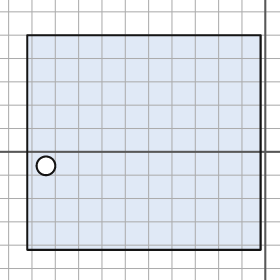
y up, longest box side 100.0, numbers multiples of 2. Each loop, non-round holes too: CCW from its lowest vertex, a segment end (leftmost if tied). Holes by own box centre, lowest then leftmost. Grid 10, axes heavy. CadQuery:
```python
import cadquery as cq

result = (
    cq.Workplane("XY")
    .moveTo(-102.0, -42.0)
    .lineTo(-2.0, -42.0)
    .lineTo(-2.0, 50.0)
    .lineTo(-102.0, 50.0)
    .close()
    .moveTo(-94.0, -6.0)
    .circle(4.0)
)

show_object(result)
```